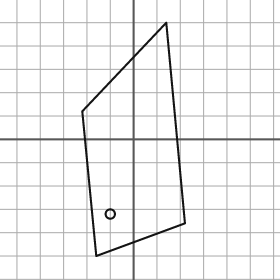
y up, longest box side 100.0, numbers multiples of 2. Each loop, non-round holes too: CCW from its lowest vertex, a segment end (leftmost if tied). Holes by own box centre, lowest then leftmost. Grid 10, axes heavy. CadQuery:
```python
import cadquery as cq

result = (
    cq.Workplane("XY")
    .moveTo(-16.0, -50.0)
    .lineTo(22.0, -36.0)
    .lineTo(14.0, 50.0)
    .lineTo(-22.0, 12.0)
    .close()
    .moveTo(-10.0, -32.0)
    .circle(2.0)
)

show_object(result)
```